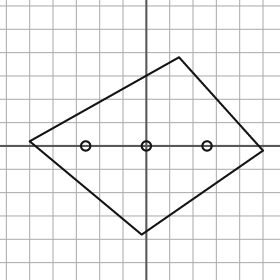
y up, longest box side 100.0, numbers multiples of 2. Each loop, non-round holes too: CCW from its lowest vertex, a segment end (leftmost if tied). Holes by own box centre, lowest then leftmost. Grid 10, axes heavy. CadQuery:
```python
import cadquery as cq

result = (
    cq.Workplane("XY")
    .moveTo(-2.0, -38.0)
    .lineTo(50.0, -2.0)
    .lineTo(14.0, 38.0)
    .lineTo(-50.0, 2.0)
    .close()
    .moveTo(-26.0, 0.0)
    .circle(2.0)
    .moveTo(0.0, 0.0)
    .circle(2.0)
    .moveTo(26.0, 0.0)
    .circle(2.0)
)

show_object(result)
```